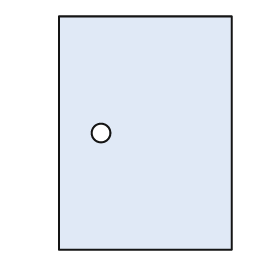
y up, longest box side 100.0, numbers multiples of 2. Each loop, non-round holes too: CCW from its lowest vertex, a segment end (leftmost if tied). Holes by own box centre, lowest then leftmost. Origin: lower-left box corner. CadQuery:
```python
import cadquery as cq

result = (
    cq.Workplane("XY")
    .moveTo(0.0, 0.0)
    .lineTo(74.0, 0.0)
    .lineTo(74.0, 100.0)
    .lineTo(0.0, 100.0)
    .close()
    .moveTo(18.0, 50.0)
    .circle(4.0)
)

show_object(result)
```